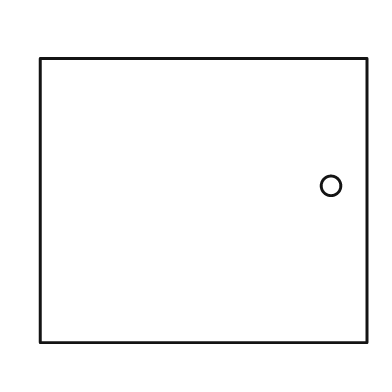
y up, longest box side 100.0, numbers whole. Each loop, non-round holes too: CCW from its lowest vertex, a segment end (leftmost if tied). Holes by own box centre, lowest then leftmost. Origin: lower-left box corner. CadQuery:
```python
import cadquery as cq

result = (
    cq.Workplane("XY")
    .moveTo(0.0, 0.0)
    .lineTo(100.0, 0.0)
    .lineTo(100.0, 87.0)
    .lineTo(0.0, 87.0)
    .close()
    .moveTo(89.0, 48.0)
    .circle(3.0)
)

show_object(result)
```